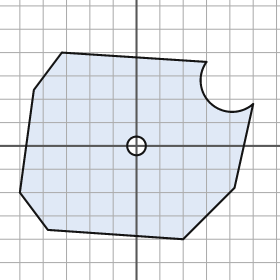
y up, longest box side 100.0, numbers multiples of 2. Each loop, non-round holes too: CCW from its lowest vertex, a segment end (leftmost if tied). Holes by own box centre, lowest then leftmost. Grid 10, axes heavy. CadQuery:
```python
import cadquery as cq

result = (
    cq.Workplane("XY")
    .moveTo(20.0, -40.0)
    .lineTo(42.0, -18.0)
    .lineTo(50.0, 18.0)
    .threePointArc((32.0, 18.0), (30.0, 36.0))
    .lineTo(-32.0, 40.0)
    .lineTo(-44.0, 24.0)
    .lineTo(-50.0, -20.0)
    .lineTo(-38.0, -36.0)
    .close()
    .moveTo(0.0, 0.0)
    .circle(4.0)
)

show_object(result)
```